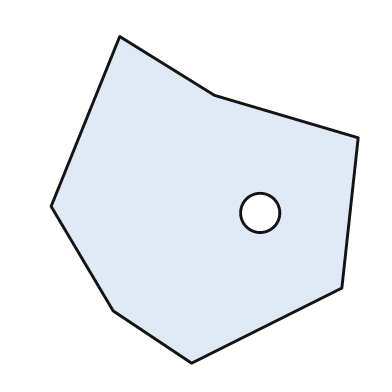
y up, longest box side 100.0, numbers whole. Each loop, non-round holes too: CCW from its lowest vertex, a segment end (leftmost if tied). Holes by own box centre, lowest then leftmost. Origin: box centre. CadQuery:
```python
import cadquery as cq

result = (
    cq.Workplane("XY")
    .moveTo(-4.0, -50.0)
    .lineTo(42.0, -27.0)
    .lineTo(47.0, 19.0)
    .lineTo(3.0, 32.0)
    .lineTo(-26.0, 50.0)
    .lineTo(-47.0, -2.0)
    .lineTo(-28.0, -34.0)
    .close()
    .moveTo(17.0, -4.0)
    .circle(6.0)
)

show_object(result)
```